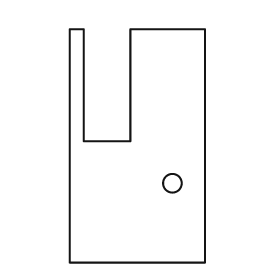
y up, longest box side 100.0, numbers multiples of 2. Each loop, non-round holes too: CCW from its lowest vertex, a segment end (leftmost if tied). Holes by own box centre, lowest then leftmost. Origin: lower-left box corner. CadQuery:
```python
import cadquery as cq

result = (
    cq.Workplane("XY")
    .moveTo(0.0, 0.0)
    .lineTo(58.0, 0.0)
    .lineTo(58.0, 100.0)
    .lineTo(26.0, 100.0)
    .lineTo(26.0, 52.0)
    .lineTo(6.0, 52.0)
    .lineTo(6.0, 100.0)
    .lineTo(0.0, 100.0)
    .close()
    .moveTo(44.0, 34.0)
    .circle(4.0)
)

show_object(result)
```